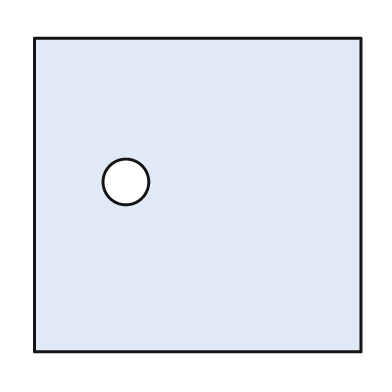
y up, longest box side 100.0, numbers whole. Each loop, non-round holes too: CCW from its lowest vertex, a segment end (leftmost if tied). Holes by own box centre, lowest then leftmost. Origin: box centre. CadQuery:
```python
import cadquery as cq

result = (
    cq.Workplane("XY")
    .moveTo(-50.0, -48.0)
    .lineTo(50.0, -48.0)
    .lineTo(50.0, 48.0)
    .lineTo(-50.0, 48.0)
    .close()
    .moveTo(-22.0, 4.0)
    .circle(7.0)
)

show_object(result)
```